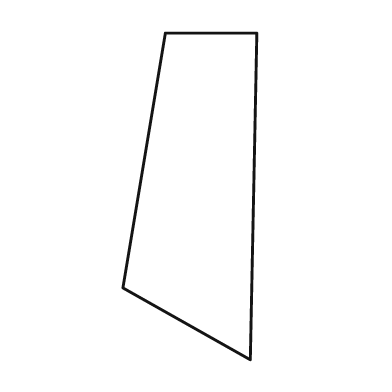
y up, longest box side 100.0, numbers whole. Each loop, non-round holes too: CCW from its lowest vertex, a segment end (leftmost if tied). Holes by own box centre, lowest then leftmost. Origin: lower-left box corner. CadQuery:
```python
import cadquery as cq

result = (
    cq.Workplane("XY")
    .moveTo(39.0, 0.0)
    .lineTo(41.0, 100.0)
    .lineTo(13.0, 100.0)
    .lineTo(0.0, 22.0)
    .close()
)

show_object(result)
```